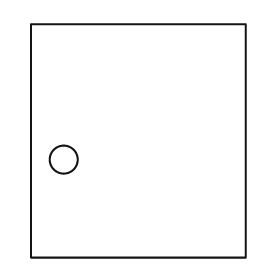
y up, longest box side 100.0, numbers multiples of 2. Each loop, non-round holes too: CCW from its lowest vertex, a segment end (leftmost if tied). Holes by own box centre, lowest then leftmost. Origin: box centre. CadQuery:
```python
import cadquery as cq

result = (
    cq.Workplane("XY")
    .moveTo(-46.0, -50.0)
    .lineTo(46.0, -50.0)
    .lineTo(46.0, 50.0)
    .lineTo(-46.0, 50.0)
    .close()
    .moveTo(-32.0, -8.0)
    .circle(6.0)
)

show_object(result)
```